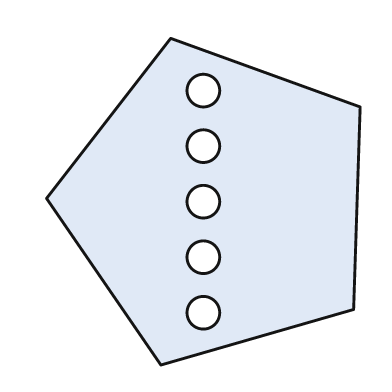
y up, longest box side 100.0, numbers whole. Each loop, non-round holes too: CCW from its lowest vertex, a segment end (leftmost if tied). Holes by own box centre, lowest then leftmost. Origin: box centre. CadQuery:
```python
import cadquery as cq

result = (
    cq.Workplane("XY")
    .moveTo(-13.0, -50.0)
    .lineTo(46.0, -33.0)
    .lineTo(48.0, 29.0)
    .lineTo(-10.0, 50.0)
    .lineTo(-48.0, 1.0)
    .close()
    .moveTo(0.0, -34.0)
    .circle(5.0)
    .moveTo(0.0, -17.0)
    .circle(5.0)
    .moveTo(0.0, 0.0)
    .circle(5.0)
    .moveTo(0.0, 17.0)
    .circle(5.0)
    .moveTo(0.0, 34.0)
    .circle(5.0)
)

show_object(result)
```